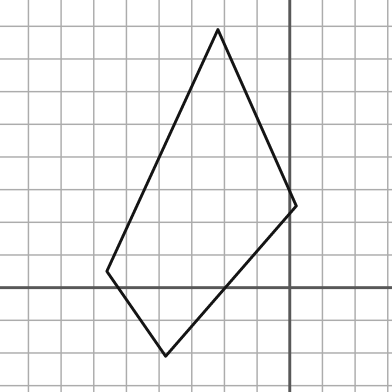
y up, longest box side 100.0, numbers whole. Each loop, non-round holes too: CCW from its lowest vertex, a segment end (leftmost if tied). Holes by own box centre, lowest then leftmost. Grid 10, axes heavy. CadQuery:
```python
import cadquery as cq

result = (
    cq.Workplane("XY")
    .moveTo(-38.0, -21.0)
    .lineTo(2.0, 25.0)
    .lineTo(-22.0, 79.0)
    .lineTo(-56.0, 5.0)
    .close()
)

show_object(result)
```